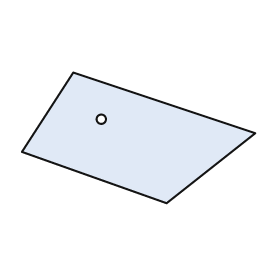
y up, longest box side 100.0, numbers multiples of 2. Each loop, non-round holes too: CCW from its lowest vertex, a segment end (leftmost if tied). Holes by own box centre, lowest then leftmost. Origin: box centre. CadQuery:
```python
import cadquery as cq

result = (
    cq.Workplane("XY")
    .moveTo(12.0, -28.0)
    .lineTo(50.0, 2.0)
    .lineTo(-28.0, 28.0)
    .lineTo(-50.0, -6.0)
    .close()
    .moveTo(-16.0, 8.0)
    .circle(2.0)
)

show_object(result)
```